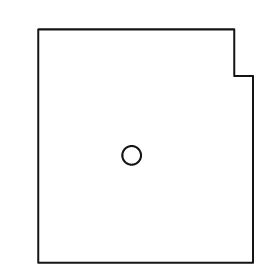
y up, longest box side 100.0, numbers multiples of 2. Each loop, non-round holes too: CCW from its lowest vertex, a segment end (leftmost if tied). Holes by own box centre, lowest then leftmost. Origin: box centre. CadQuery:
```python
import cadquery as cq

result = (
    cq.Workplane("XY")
    .moveTo(-46.0, -50.0)
    .lineTo(46.0, -50.0)
    .lineTo(46.0, 30.0)
    .lineTo(38.0, 30.0)
    .lineTo(38.0, 50.0)
    .lineTo(-46.0, 50.0)
    .close()
    .moveTo(-6.0, -4.0)
    .circle(4.0)
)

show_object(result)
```